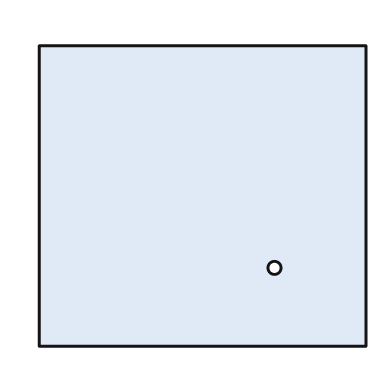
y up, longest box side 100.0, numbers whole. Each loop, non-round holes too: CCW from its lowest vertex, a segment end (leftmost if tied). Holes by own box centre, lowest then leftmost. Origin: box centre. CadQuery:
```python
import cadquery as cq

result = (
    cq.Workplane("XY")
    .moveTo(-50.0, -46.0)
    .lineTo(50.0, -46.0)
    .lineTo(50.0, 46.0)
    .lineTo(-50.0, 46.0)
    .close()
    .moveTo(22.0, -22.0)
    .circle(2.0)
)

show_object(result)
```